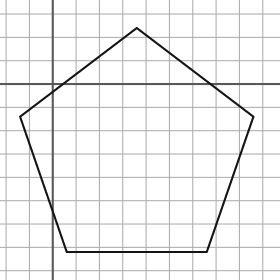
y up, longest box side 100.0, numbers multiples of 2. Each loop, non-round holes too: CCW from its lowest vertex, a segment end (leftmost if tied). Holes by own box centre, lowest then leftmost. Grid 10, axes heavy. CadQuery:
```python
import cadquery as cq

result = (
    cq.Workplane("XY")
    .moveTo(6.0, -72.0)
    .lineTo(66.0, -72.0)
    .lineTo(86.0, -14.0)
    .lineTo(36.0, 24.0)
    .lineTo(-14.0, -14.0)
    .close()
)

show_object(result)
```